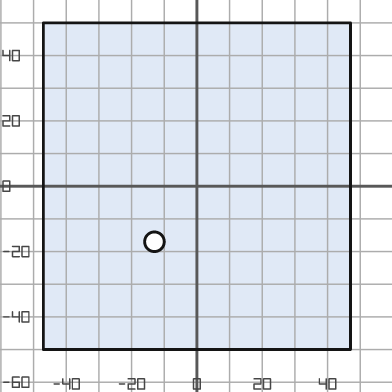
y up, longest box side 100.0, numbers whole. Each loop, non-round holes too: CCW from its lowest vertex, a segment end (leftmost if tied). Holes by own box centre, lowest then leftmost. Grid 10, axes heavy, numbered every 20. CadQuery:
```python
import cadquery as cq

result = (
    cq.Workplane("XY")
    .moveTo(-47.0, -50.0)
    .lineTo(47.0, -50.0)
    .lineTo(47.0, 50.0)
    .lineTo(-47.0, 50.0)
    .close()
    .moveTo(-13.0, -17.0)
    .circle(3.0)
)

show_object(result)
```